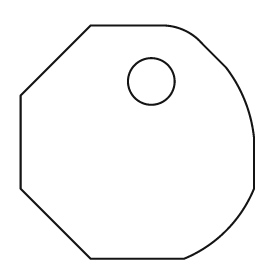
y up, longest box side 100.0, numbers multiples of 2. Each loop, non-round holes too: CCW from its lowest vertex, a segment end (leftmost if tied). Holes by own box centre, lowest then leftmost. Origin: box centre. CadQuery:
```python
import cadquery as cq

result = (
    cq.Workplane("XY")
    .moveTo(-20.0, -50.0)
    .lineTo(20.0, -50.0)
    .threePointArc((38.0, -38.0), (50.0, -20.0))
    .lineTo(50.0, 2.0)
    .threePointArc((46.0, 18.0), (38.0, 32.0))
    .lineTo(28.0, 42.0)
    .threePointArc((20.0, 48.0), (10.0, 50.0))
    .lineTo(-20.0, 50.0)
    .lineTo(-50.0, 20.0)
    .lineTo(-50.0, -20.0)
    .close()
    .moveTo(6.0, 26.0)
    .circle(10.0)
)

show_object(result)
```